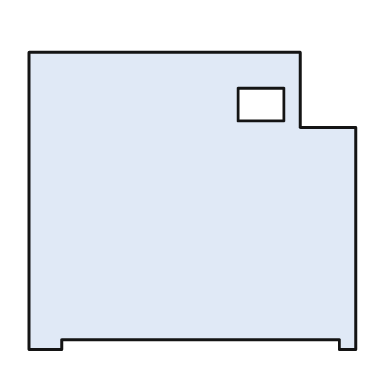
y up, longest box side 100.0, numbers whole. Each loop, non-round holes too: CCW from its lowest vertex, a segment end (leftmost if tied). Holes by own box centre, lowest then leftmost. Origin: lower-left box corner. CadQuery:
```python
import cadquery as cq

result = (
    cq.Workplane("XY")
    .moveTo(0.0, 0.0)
    .lineTo(10.0, 0.0)
    .lineTo(10.0, 3.0)
    .lineTo(95.0, 3.0)
    .lineTo(95.0, 0.0)
    .lineTo(100.0, 0.0)
    .lineTo(100.0, 68.0)
    .lineTo(83.0, 68.0)
    .lineTo(83.0, 91.0)
    .lineTo(0.0, 91.0)
    .close()
    .moveTo(64.0, 70.0)
    .lineTo(78.0, 70.0)
    .lineTo(78.0, 80.0)
    .lineTo(64.0, 80.0)
    .close()
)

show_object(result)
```